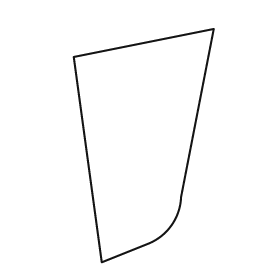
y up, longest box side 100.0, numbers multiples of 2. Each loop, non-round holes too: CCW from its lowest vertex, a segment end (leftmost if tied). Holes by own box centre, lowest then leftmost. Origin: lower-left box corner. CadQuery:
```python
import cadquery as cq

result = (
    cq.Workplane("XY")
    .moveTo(12.0, 0.0)
    .lineTo(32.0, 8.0)
    .threePointArc((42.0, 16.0), (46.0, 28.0))
    .lineTo(60.0, 100.0)
    .lineTo(0.0, 88.0)
    .close()
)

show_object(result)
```